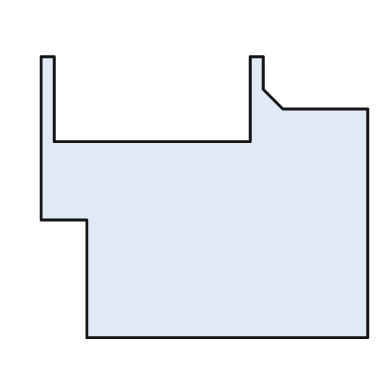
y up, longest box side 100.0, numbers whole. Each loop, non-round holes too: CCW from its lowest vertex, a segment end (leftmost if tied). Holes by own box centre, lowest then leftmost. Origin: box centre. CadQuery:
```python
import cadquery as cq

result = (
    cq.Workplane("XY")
    .moveTo(-36.0, -43.0)
    .lineTo(50.0, -43.0)
    .lineTo(50.0, 27.0)
    .lineTo(24.0, 27.0)
    .lineTo(18.0, 33.0)
    .lineTo(18.0, 43.0)
    .lineTo(14.0, 43.0)
    .lineTo(14.0, 17.0)
    .lineTo(-46.0, 17.0)
    .lineTo(-46.0, 43.0)
    .lineTo(-50.0, 43.0)
    .lineTo(-50.0, -7.0)
    .lineTo(-36.0, -7.0)
    .close()
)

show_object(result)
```